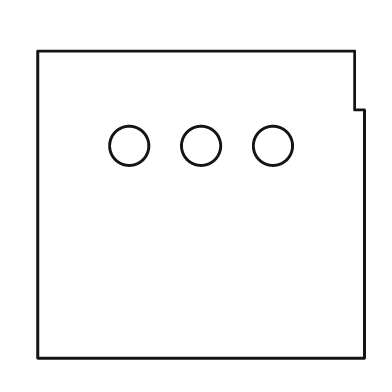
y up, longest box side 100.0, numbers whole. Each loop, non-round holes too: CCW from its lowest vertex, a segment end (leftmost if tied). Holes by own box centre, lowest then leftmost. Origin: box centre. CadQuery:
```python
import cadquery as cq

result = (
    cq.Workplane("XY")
    .moveTo(-50.0, -47.0)
    .lineTo(50.0, -47.0)
    .lineTo(50.0, 29.0)
    .lineTo(47.0, 29.0)
    .lineTo(47.0, 47.0)
    .lineTo(-50.0, 47.0)
    .close()
    .moveTo(-22.0, 18.0)
    .circle(6.0)
    .moveTo(0.0, 18.0)
    .circle(6.0)
    .moveTo(22.0, 18.0)
    .circle(6.0)
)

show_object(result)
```